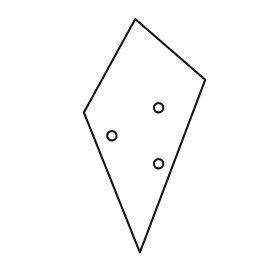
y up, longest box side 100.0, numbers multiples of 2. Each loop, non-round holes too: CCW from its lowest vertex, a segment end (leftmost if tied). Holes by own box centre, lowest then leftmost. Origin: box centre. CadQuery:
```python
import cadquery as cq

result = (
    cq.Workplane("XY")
    .moveTo(-2.0, -50.0)
    .lineTo(26.0, 24.0)
    .lineTo(-4.0, 50.0)
    .lineTo(-26.0, 10.0)
    .close()
    .moveTo(6.0, -12.0)
    .circle(2.0)
    .moveTo(-14.0, 0.0)
    .circle(2.0)
    .moveTo(6.0, 12.0)
    .circle(2.0)
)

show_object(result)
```